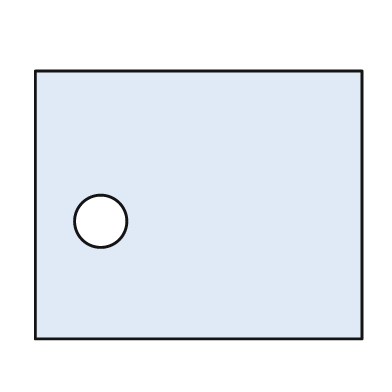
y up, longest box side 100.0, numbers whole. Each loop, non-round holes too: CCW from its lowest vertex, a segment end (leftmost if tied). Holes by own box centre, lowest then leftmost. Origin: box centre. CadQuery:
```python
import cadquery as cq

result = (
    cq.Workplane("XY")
    .moveTo(-50.0, -41.0)
    .lineTo(50.0, -41.0)
    .lineTo(50.0, 41.0)
    .lineTo(-50.0, 41.0)
    .close()
    .moveTo(-30.0, -5.0)
    .circle(8.0)
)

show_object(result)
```